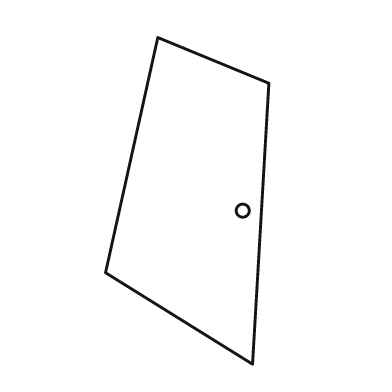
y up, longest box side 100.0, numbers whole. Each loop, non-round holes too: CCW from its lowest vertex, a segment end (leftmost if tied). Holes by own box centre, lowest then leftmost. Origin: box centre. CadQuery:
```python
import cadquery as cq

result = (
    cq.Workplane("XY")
    .moveTo(20.0, -50.0)
    .lineTo(25.0, 36.0)
    .lineTo(-9.0, 50.0)
    .lineTo(-25.0, -22.0)
    .close()
    .moveTo(17.0, -3.0)
    .circle(2.0)
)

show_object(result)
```